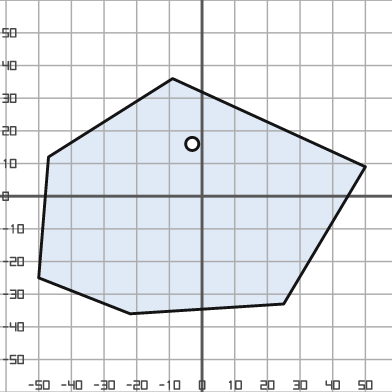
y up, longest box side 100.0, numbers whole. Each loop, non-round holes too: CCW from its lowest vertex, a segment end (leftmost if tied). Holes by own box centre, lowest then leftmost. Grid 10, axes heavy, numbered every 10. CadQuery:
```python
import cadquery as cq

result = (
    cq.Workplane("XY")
    .moveTo(-22.0, -36.0)
    .lineTo(25.0, -33.0)
    .lineTo(50.0, 9.0)
    .lineTo(-9.0, 36.0)
    .lineTo(-47.0, 12.0)
    .lineTo(-50.0, -25.0)
    .close()
    .moveTo(-3.0, 16.0)
    .circle(2.0)
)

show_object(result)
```